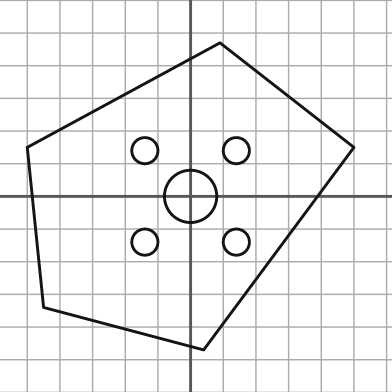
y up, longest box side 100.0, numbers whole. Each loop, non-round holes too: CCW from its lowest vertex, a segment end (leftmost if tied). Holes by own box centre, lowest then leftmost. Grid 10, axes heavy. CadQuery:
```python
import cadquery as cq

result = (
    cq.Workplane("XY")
    .moveTo(4.0, -47.0)
    .lineTo(50.0, 15.0)
    .lineTo(9.0, 47.0)
    .lineTo(-50.0, 15.0)
    .lineTo(-45.0, -34.0)
    .close()
    .moveTo(-14.0, -14.0)
    .circle(4.0)
    .moveTo(14.0, -14.0)
    .circle(4.0)
    .moveTo(0.0, 0.0)
    .circle(8.0)
    .moveTo(-14.0, 14.0)
    .circle(4.0)
    .moveTo(14.0, 14.0)
    .circle(4.0)
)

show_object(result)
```